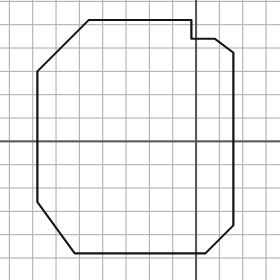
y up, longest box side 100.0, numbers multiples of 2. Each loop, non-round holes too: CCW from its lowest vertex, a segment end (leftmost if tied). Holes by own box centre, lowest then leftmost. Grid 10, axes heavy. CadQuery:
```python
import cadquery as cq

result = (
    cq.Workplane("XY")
    .moveTo(-52.0, -48.0)
    .lineTo(4.0, -48.0)
    .lineTo(16.0, -36.0)
    .lineTo(16.0, 38.0)
    .lineTo(8.0, 44.0)
    .lineTo(-2.0, 44.0)
    .lineTo(-2.0, 52.0)
    .lineTo(-46.0, 52.0)
    .lineTo(-68.0, 30.0)
    .lineTo(-68.0, -26.0)
    .close()
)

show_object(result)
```